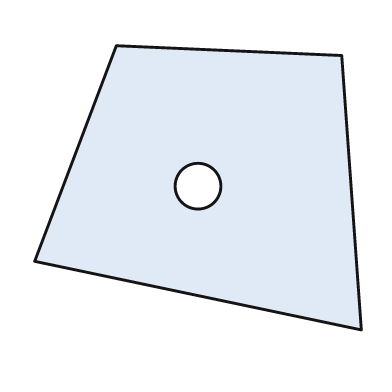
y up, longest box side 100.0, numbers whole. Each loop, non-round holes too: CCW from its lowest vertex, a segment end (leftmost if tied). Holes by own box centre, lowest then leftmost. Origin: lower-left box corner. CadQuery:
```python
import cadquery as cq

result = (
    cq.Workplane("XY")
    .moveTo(100.0, 0.0)
    .lineTo(94.0, 84.0)
    .lineTo(25.0, 87.0)
    .lineTo(0.0, 21.0)
    .close()
    .moveTo(50.0, 44.0)
    .circle(7.0)
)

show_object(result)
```